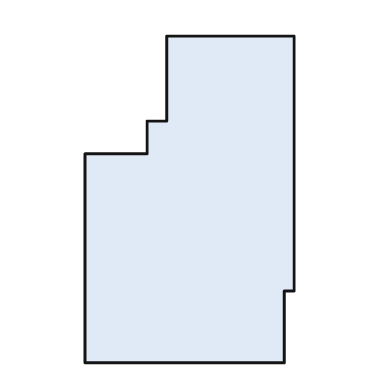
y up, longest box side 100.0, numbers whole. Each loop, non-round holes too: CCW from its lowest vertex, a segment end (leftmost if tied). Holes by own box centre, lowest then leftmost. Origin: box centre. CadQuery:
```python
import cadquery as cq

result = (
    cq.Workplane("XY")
    .moveTo(-32.0, -50.0)
    .lineTo(29.0, -50.0)
    .lineTo(29.0, -28.0)
    .lineTo(32.0, -28.0)
    .lineTo(32.0, 50.0)
    .lineTo(-7.0, 50.0)
    .lineTo(-7.0, 24.0)
    .lineTo(-13.0, 24.0)
    .lineTo(-13.0, 14.0)
    .lineTo(-32.0, 14.0)
    .close()
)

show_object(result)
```